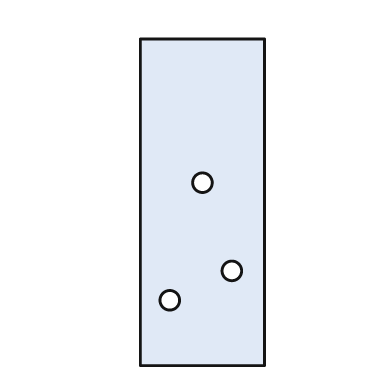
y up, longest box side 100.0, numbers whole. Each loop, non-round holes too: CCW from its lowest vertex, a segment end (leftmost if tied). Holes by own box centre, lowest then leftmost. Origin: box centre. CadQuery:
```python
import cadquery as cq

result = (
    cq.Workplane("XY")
    .moveTo(-19.0, -50.0)
    .lineTo(19.0, -50.0)
    .lineTo(19.0, 50.0)
    .lineTo(-19.0, 50.0)
    .close()
    .moveTo(-10.0, -30.0)
    .circle(3.0)
    .moveTo(9.0, -21.0)
    .circle(3.0)
    .moveTo(0.0, 6.0)
    .circle(3.0)
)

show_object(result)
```